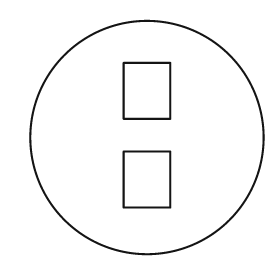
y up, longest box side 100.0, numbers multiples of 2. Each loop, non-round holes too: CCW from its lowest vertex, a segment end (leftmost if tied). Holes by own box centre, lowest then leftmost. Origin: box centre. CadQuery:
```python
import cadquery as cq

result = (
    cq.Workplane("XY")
    .moveTo(0.0, 0.0)
    .circle(50.0)
    .moveTo(-10.0, -30.0)
    .lineTo(10.0, -30.0)
    .lineTo(10.0, -6.0)
    .lineTo(-10.0, -6.0)
    .close()
    .moveTo(-10.0, 8.0)
    .lineTo(10.0, 8.0)
    .lineTo(10.0, 32.0)
    .lineTo(-10.0, 32.0)
    .close()
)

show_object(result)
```